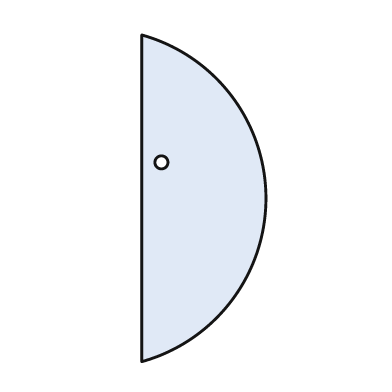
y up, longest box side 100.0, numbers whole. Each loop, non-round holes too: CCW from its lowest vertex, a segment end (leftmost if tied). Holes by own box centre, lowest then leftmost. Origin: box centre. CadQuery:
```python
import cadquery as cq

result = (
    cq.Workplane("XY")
    .moveTo(-19.0, -50.0)
    .threePointArc((19.0, 0.0), (-19.0, 50.0))
    .close()
    .moveTo(-13.0, 11.0)
    .circle(2.0)
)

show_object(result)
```